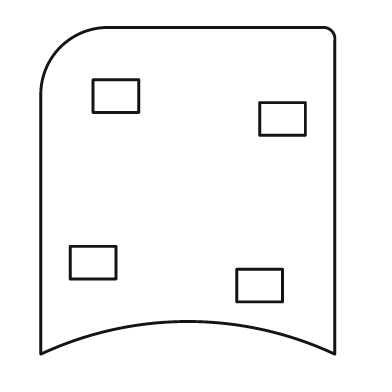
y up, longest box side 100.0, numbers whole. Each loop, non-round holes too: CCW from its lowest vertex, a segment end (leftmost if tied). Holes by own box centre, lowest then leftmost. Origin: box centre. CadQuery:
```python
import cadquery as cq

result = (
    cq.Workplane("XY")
    .moveTo(-45.0, -50.0)
    .threePointArc((0.0, -40.0), (45.0, -50.0))
    .lineTo(45.0, 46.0)
    .threePointArc((44.0, 49.0), (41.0, 50.0))
    .lineTo(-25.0, 50.0)
    .threePointArc((-39.0, 44.0), (-45.0, 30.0))
    .close()
    .moveTo(15.0, -34.0)
    .lineTo(29.0, -34.0)
    .lineTo(29.0, -24.0)
    .lineTo(15.0, -24.0)
    .close()
    .moveTo(-36.0, -27.0)
    .lineTo(-22.0, -27.0)
    .lineTo(-22.0, -17.0)
    .lineTo(-36.0, -17.0)
    .close()
    .moveTo(22.0, 17.0)
    .lineTo(36.0, 17.0)
    .lineTo(36.0, 27.0)
    .lineTo(22.0, 27.0)
    .close()
    .moveTo(-29.0, 24.0)
    .lineTo(-15.0, 24.0)
    .lineTo(-15.0, 34.0)
    .lineTo(-29.0, 34.0)
    .close()
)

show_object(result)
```